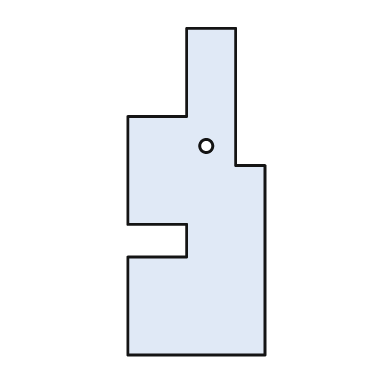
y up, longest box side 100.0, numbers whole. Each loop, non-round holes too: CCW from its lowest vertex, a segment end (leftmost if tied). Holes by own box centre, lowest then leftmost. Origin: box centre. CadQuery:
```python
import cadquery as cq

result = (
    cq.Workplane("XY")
    .moveTo(-21.0, -50.0)
    .lineTo(21.0, -50.0)
    .lineTo(21.0, 8.0)
    .lineTo(12.0, 8.0)
    .lineTo(12.0, 50.0)
    .lineTo(-3.0, 50.0)
    .lineTo(-3.0, 23.0)
    .lineTo(-21.0, 23.0)
    .lineTo(-21.0, -10.0)
    .lineTo(-3.0, -10.0)
    .lineTo(-3.0, -20.0)
    .lineTo(-21.0, -20.0)
    .close()
    .moveTo(3.0, 14.0)
    .circle(2.0)
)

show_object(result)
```